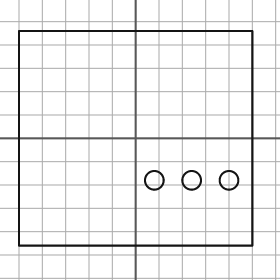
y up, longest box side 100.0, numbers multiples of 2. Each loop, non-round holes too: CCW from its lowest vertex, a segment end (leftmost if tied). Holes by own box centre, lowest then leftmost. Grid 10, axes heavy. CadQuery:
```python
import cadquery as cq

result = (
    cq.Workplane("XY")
    .moveTo(-50.0, -46.0)
    .lineTo(50.0, -46.0)
    .lineTo(50.0, 46.0)
    .lineTo(-50.0, 46.0)
    .close()
    .moveTo(8.0, -18.0)
    .circle(4.0)
    .moveTo(24.0, -18.0)
    .circle(4.0)
    .moveTo(40.0, -18.0)
    .circle(4.0)
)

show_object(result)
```